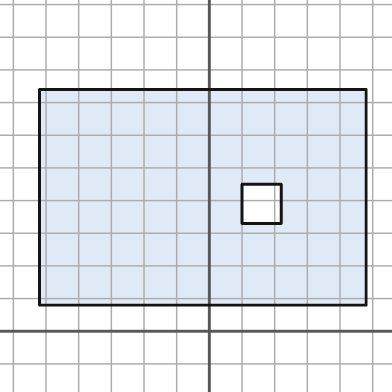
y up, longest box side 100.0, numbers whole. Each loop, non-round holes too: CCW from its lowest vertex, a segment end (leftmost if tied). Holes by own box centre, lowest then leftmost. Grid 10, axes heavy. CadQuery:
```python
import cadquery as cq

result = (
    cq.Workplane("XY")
    .moveTo(-52.0, 8.0)
    .lineTo(48.0, 8.0)
    .lineTo(48.0, 74.0)
    .lineTo(-52.0, 74.0)
    .close()
    .moveTo(10.0, 33.0)
    .lineTo(22.0, 33.0)
    .lineTo(22.0, 45.0)
    .lineTo(10.0, 45.0)
    .close()
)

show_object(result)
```